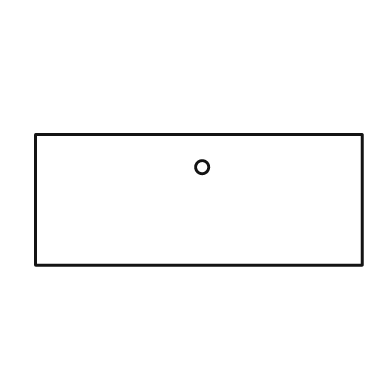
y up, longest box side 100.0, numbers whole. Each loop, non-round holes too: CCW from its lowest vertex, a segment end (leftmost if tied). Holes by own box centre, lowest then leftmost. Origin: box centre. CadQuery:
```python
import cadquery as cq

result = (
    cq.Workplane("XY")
    .moveTo(-50.0, -20.0)
    .lineTo(50.0, -20.0)
    .lineTo(50.0, 20.0)
    .lineTo(-50.0, 20.0)
    .close()
    .moveTo(1.0, 10.0)
    .circle(2.0)
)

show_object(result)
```